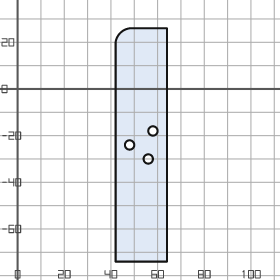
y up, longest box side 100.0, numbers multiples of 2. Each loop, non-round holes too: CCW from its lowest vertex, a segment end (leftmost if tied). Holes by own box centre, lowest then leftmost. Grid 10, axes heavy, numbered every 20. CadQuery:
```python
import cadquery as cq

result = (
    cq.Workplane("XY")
    .moveTo(42.0, -74.0)
    .lineTo(64.0, -74.0)
    .lineTo(64.0, 26.0)
    .lineTo(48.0, 26.0)
    .threePointArc((44.0, 24.0), (42.0, 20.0))
    .close()
    .moveTo(56.0, -30.0)
    .circle(2.0)
    .moveTo(48.0, -24.0)
    .circle(2.0)
    .moveTo(58.0, -18.0)
    .circle(2.0)
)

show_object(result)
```